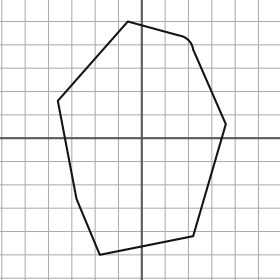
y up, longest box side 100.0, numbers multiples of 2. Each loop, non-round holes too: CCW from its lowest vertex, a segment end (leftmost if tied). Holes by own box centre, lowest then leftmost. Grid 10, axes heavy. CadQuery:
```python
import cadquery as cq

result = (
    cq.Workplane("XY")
    .moveTo(-18.0, -50.0)
    .lineTo(22.0, -42.0)
    .lineTo(36.0, 6.0)
    .lineTo(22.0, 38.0)
    .threePointArc((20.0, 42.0), (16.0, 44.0))
    .lineTo(-6.0, 50.0)
    .lineTo(-36.0, 16.0)
    .lineTo(-28.0, -26.0)
    .close()
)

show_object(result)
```